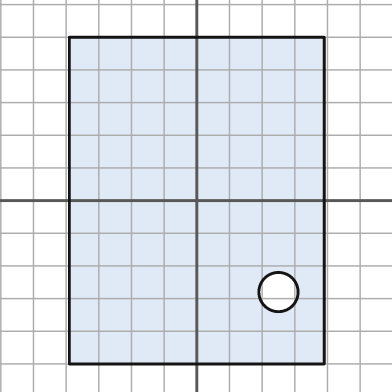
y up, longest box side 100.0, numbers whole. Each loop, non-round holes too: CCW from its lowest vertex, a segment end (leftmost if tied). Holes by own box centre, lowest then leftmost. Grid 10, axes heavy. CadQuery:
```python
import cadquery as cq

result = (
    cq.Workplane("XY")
    .moveTo(-39.0, -50.0)
    .lineTo(39.0, -50.0)
    .lineTo(39.0, 50.0)
    .lineTo(-39.0, 50.0)
    .close()
    .moveTo(25.0, -28.0)
    .circle(6.0)
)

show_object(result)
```